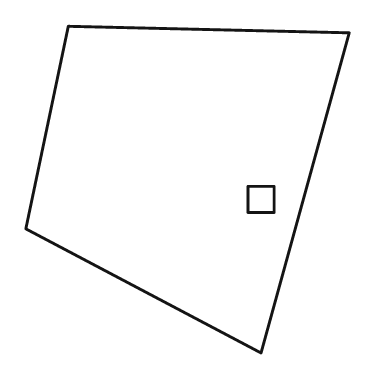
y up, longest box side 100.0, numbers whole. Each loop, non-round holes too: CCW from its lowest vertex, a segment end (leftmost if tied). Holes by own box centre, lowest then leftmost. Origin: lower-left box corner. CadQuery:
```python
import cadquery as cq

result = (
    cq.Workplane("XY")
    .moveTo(72.0, 0.0)
    .lineTo(99.0, 98.0)
    .lineTo(13.0, 100.0)
    .lineTo(0.0, 38.0)
    .close()
    .moveTo(68.0, 43.0)
    .lineTo(76.0, 43.0)
    .lineTo(76.0, 51.0)
    .lineTo(68.0, 51.0)
    .close()
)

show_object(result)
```